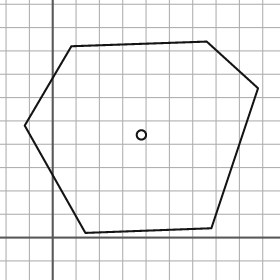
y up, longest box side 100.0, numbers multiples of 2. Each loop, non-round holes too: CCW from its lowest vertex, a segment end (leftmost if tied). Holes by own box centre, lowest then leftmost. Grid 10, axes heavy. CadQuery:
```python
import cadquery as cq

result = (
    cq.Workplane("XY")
    .moveTo(14.0, 2.0)
    .lineTo(68.0, 4.0)
    .lineTo(88.0, 64.0)
    .lineTo(66.0, 84.0)
    .lineTo(8.0, 82.0)
    .lineTo(-12.0, 48.0)
    .close()
    .moveTo(38.0, 44.0)
    .circle(2.0)
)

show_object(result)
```